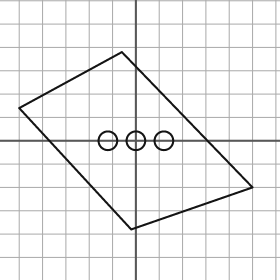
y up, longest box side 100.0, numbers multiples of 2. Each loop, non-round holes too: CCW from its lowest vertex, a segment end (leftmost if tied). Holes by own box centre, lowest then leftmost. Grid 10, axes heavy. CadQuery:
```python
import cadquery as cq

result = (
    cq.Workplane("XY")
    .moveTo(-2.0, -38.0)
    .lineTo(50.0, -20.0)
    .lineTo(-6.0, 38.0)
    .lineTo(-50.0, 14.0)
    .close()
    .moveTo(-12.0, 0.0)
    .circle(4.0)
    .moveTo(0.0, 0.0)
    .circle(4.0)
    .moveTo(12.0, 0.0)
    .circle(4.0)
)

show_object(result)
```